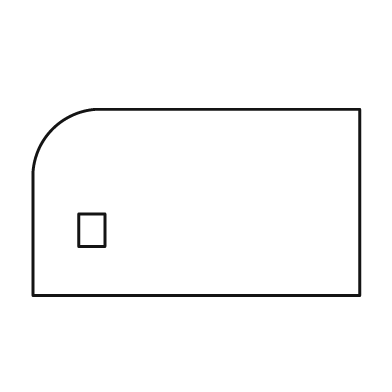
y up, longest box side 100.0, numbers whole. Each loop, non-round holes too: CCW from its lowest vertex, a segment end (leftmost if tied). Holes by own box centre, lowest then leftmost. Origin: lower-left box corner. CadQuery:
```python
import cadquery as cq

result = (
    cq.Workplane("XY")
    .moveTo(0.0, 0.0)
    .lineTo(100.0, 0.0)
    .lineTo(100.0, 57.0)
    .lineTo(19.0, 57.0)
    .threePointArc((6.0, 51.0), (0.0, 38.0))
    .close()
    .moveTo(14.0, 15.0)
    .lineTo(22.0, 15.0)
    .lineTo(22.0, 25.0)
    .lineTo(14.0, 25.0)
    .close()
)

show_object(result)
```